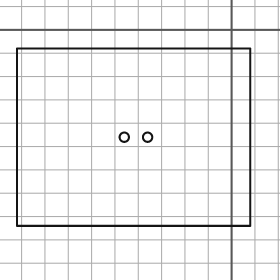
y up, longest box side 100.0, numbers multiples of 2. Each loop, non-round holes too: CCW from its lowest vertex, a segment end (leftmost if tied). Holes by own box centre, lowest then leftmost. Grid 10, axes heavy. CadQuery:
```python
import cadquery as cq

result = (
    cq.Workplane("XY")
    .moveTo(-92.0, -84.0)
    .lineTo(8.0, -84.0)
    .lineTo(8.0, -8.0)
    .lineTo(-92.0, -8.0)
    .close()
    .moveTo(-46.0, -46.0)
    .circle(2.0)
    .moveTo(-36.0, -46.0)
    .circle(2.0)
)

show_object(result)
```